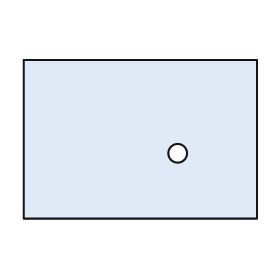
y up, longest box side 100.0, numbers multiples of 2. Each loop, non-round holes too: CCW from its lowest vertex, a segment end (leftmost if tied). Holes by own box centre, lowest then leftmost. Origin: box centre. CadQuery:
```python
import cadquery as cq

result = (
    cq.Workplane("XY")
    .moveTo(-50.0, -34.0)
    .lineTo(50.0, -34.0)
    .lineTo(50.0, 34.0)
    .lineTo(-50.0, 34.0)
    .close()
    .moveTo(16.0, -6.0)
    .circle(4.0)
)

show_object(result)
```